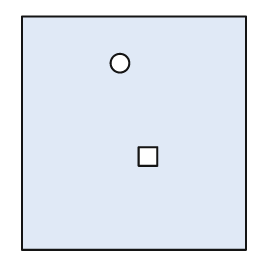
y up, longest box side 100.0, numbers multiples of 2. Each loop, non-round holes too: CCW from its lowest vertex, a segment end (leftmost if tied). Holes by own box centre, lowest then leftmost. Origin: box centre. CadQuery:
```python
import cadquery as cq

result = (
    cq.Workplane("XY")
    .moveTo(-48.0, -50.0)
    .lineTo(48.0, -50.0)
    .lineTo(48.0, 50.0)
    .lineTo(-48.0, 50.0)
    .close()
    .moveTo(2.0, -14.0)
    .lineTo(10.0, -14.0)
    .lineTo(10.0, -6.0)
    .lineTo(2.0, -6.0)
    .close()
    .moveTo(-6.0, 30.0)
    .circle(4.0)
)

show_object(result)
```